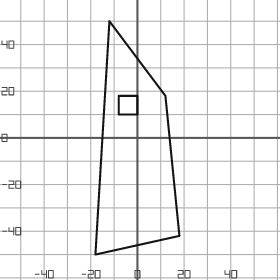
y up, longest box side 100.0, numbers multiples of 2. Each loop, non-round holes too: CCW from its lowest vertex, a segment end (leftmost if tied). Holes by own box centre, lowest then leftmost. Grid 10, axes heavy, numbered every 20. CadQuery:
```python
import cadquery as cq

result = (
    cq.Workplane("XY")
    .moveTo(-18.0, -50.0)
    .lineTo(18.0, -42.0)
    .lineTo(12.0, 18.0)
    .lineTo(-12.0, 50.0)
    .close()
    .moveTo(-8.0, 10.0)
    .lineTo(0.0, 10.0)
    .lineTo(0.0, 18.0)
    .lineTo(-8.0, 18.0)
    .close()
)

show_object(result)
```